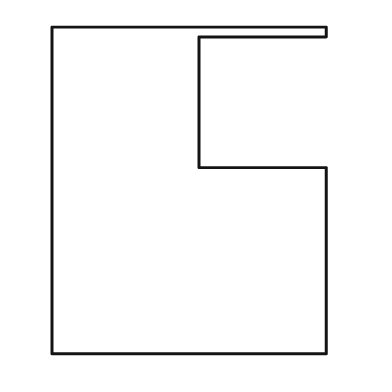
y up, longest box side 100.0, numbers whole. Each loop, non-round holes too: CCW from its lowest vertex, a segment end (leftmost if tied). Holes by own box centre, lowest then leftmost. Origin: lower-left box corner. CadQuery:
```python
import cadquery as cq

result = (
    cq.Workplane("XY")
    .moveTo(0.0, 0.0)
    .lineTo(84.0, 0.0)
    .lineTo(84.0, 57.0)
    .lineTo(45.0, 57.0)
    .lineTo(45.0, 97.0)
    .lineTo(84.0, 97.0)
    .lineTo(84.0, 100.0)
    .lineTo(0.0, 100.0)
    .close()
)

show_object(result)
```